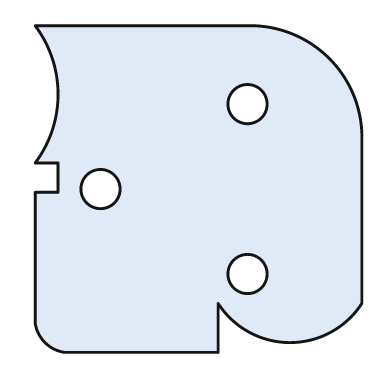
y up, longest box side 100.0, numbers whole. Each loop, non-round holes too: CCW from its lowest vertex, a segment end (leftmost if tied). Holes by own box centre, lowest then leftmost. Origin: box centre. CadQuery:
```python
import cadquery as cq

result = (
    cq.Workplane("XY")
    .moveTo(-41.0, -50.0)
    .lineTo(6.0, -50.0)
    .lineTo(6.0, -35.0)
    .threePointArc((28.0, -47.0), (50.0, -35.0))
    .lineTo(50.0, 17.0)
    .threePointArc((40.0, 40.0), (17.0, 50.0))
    .lineTo(-50.0, 50.0)
    .threePointArc((-43.0, 29.0), (-50.0, 8.0))
    .lineTo(-43.0, 8.0)
    .lineTo(-43.0, -1.0)
    .lineTo(-50.0, -1.0)
    .lineTo(-50.0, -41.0)
    .threePointArc((-47.0, -47.0), (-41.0, -50.0))
    .close()
    .moveTo(15.0, -26.0)
    .circle(6.0)
    .moveTo(-30.0, 0.0)
    .circle(6.0)
    .moveTo(15.0, 26.0)
    .circle(6.0)
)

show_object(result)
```